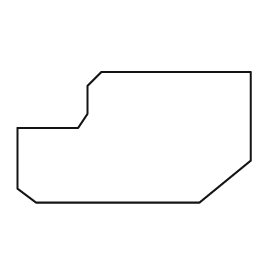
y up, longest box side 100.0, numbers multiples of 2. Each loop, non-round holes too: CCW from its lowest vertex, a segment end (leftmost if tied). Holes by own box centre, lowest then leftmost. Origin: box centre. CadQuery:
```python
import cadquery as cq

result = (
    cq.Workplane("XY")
    .moveTo(-42.0, -28.0)
    .lineTo(28.0, -28.0)
    .lineTo(50.0, -10.0)
    .lineTo(50.0, 28.0)
    .lineTo(-14.0, 28.0)
    .lineTo(-20.0, 22.0)
    .lineTo(-20.0, 10.0)
    .lineTo(-24.0, 4.0)
    .lineTo(-50.0, 4.0)
    .lineTo(-50.0, -22.0)
    .close()
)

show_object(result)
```